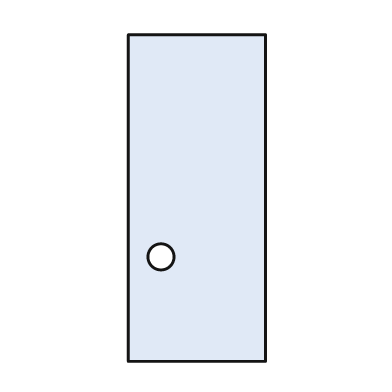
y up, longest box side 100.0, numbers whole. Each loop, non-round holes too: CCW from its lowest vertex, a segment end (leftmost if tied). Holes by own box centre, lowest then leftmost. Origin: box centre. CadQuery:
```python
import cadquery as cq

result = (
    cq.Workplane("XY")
    .moveTo(-21.0, -50.0)
    .lineTo(21.0, -50.0)
    .lineTo(21.0, 50.0)
    .lineTo(-21.0, 50.0)
    .close()
    .moveTo(-11.0, -18.0)
    .circle(4.0)
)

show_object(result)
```